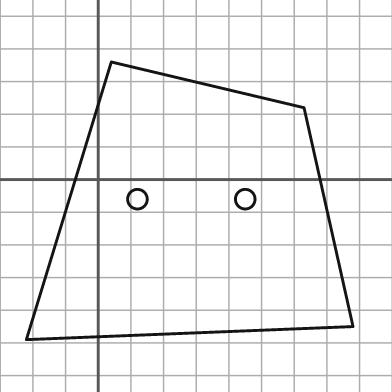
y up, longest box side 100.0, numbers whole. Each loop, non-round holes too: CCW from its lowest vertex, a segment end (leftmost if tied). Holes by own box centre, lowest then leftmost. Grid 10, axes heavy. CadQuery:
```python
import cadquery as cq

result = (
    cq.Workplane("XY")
    .moveTo(-22.0, -49.0)
    .lineTo(78.0, -45.0)
    .lineTo(63.0, 22.0)
    .lineTo(4.0, 36.0)
    .close()
    .moveTo(12.0, -6.0)
    .circle(3.0)
    .moveTo(45.0, -6.0)
    .circle(3.0)
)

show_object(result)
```